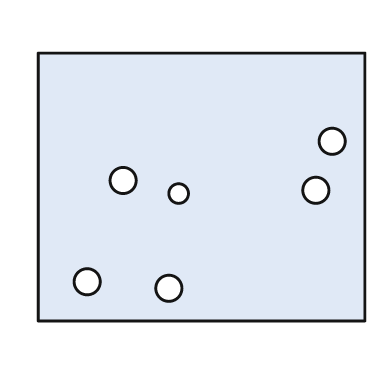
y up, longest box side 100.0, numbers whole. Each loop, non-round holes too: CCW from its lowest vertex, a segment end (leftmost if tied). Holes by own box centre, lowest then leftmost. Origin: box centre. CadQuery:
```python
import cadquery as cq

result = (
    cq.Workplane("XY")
    .moveTo(-50.0, -41.0)
    .lineTo(50.0, -41.0)
    .lineTo(50.0, 41.0)
    .lineTo(-50.0, 41.0)
    .close()
    .moveTo(-10.0, -31.0)
    .circle(4.0)
    .moveTo(-35.0, -29.0)
    .circle(4.0)
    .moveTo(-7.0, -2.0)
    .circle(3.0)
    .moveTo(35.0, -1.0)
    .circle(4.0)
    .moveTo(-24.0, 2.0)
    .circle(4.0)
    .moveTo(40.0, 14.0)
    .circle(4.0)
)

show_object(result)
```